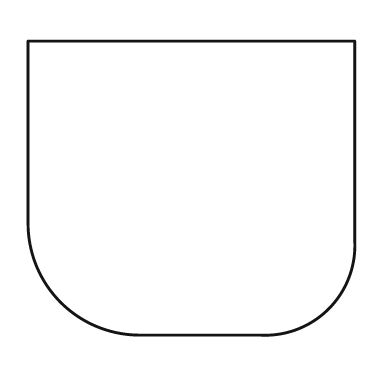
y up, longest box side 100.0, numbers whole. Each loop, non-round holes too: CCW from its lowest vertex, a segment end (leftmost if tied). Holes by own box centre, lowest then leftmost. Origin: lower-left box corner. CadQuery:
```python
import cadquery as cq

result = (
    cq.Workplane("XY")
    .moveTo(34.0, 0.0)
    .lineTo(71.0, 0.0)
    .threePointArc((92.0, 8.0), (100.0, 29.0))
    .lineTo(100.0, 90.0)
    .lineTo(0.0, 90.0)
    .lineTo(0.0, 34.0)
    .threePointArc((10.0, 10.0), (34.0, 0.0))
    .close()
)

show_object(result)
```